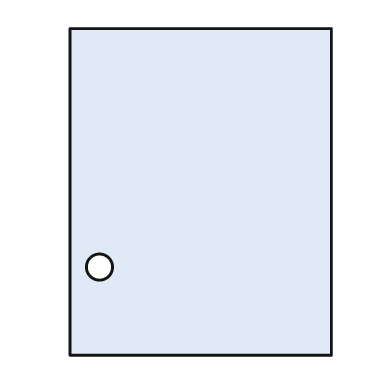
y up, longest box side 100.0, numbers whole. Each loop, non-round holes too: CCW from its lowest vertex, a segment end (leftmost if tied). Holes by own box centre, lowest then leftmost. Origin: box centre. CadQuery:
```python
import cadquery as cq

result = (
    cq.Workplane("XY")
    .moveTo(-40.0, -50.0)
    .lineTo(40.0, -50.0)
    .lineTo(40.0, 50.0)
    .lineTo(-40.0, 50.0)
    .close()
    .moveTo(-31.0, -23.0)
    .circle(4.0)
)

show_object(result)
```